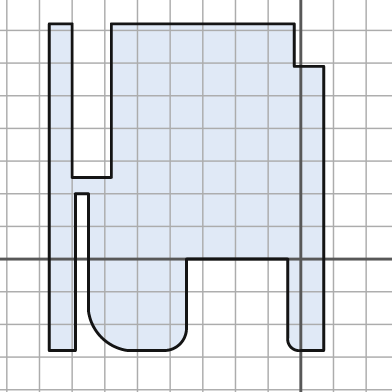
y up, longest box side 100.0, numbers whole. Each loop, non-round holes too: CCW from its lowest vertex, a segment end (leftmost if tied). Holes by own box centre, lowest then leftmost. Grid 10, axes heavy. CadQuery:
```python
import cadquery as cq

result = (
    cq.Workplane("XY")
    .moveTo(-77.0, -28.0)
    .lineTo(-69.0, -28.0)
    .lineTo(-69.0, 20.0)
    .lineTo(-65.0, 20.0)
    .lineTo(-65.0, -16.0)
    .threePointArc((-61.0, -24.0), (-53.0, -28.0))
    .lineTo(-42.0, -28.0)
    .threePointArc((-37.0, -26.0), (-35.0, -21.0))
    .lineTo(-35.0, 0.0)
    .lineTo(-4.0, 0.0)
    .lineTo(-4.0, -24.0)
    .threePointArc((-3.0, -27.0), (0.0, -28.0))
    .lineTo(7.0, -28.0)
    .lineTo(7.0, 59.0)
    .lineTo(-2.0, 59.0)
    .lineTo(-2.0, 72.0)
    .lineTo(-58.0, 72.0)
    .lineTo(-58.0, 25.0)
    .lineTo(-70.0, 25.0)
    .lineTo(-70.0, 72.0)
    .lineTo(-77.0, 72.0)
    .close()
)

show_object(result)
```